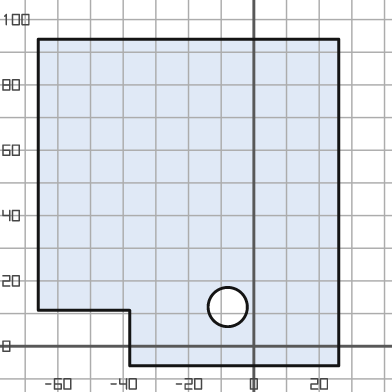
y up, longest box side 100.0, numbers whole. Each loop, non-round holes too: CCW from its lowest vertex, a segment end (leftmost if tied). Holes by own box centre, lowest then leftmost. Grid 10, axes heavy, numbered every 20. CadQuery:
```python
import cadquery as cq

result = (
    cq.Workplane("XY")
    .moveTo(-38.0, -6.0)
    .lineTo(26.0, -6.0)
    .lineTo(26.0, 94.0)
    .lineTo(-66.0, 94.0)
    .lineTo(-66.0, 11.0)
    .lineTo(-38.0, 11.0)
    .close()
    .moveTo(-8.0, 12.0)
    .circle(6.0)
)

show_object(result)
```